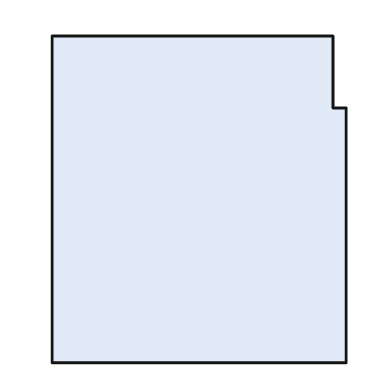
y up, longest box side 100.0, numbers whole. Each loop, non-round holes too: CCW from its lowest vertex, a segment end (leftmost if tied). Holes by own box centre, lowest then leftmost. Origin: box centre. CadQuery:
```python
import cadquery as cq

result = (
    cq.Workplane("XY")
    .moveTo(-45.0, -50.0)
    .lineTo(45.0, -50.0)
    .lineTo(45.0, 28.0)
    .lineTo(41.0, 28.0)
    .lineTo(41.0, 50.0)
    .lineTo(-45.0, 50.0)
    .close()
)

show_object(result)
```